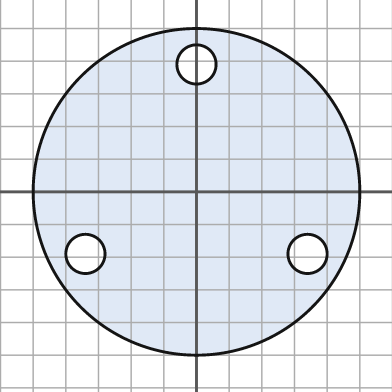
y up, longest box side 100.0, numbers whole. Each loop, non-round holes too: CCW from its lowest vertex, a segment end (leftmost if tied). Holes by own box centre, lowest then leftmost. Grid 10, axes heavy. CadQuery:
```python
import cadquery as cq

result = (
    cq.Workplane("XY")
    .moveTo(0.0, 0.0)
    .circle(50.0)
    .moveTo(-34.0, -19.0)
    .circle(6.0)
    .moveTo(34.0, -19.0)
    .circle(6.0)
    .moveTo(0.0, 39.0)
    .circle(6.0)
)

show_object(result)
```